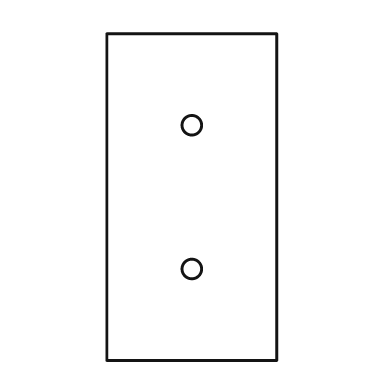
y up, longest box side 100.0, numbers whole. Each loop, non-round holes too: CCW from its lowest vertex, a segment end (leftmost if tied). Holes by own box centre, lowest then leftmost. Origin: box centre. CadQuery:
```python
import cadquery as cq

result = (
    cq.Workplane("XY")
    .moveTo(-26.0, -50.0)
    .lineTo(26.0, -50.0)
    .lineTo(26.0, 50.0)
    .lineTo(-26.0, 50.0)
    .close()
    .moveTo(0.0, -22.0)
    .circle(3.0)
    .moveTo(0.0, 22.0)
    .circle(3.0)
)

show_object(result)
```